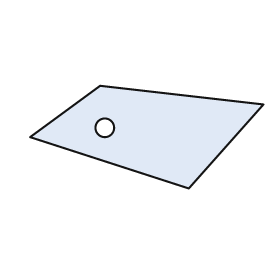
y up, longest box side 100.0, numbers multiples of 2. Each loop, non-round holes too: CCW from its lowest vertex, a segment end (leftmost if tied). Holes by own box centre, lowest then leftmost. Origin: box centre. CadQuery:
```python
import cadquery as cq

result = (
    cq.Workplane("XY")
    .moveTo(18.0, -22.0)
    .lineTo(50.0, 14.0)
    .lineTo(-20.0, 22.0)
    .lineTo(-50.0, 0.0)
    .close()
    .moveTo(-18.0, 4.0)
    .circle(4.0)
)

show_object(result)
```